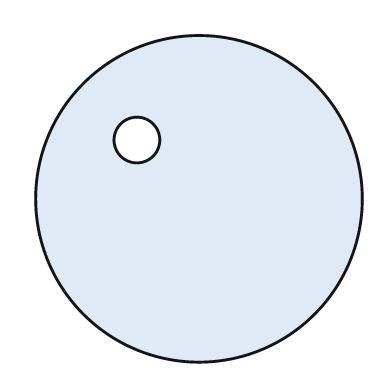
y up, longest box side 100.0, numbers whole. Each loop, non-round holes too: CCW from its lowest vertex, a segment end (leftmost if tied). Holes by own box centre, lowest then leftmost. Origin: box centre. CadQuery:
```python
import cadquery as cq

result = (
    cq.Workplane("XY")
    .moveTo(0.0, 0.0)
    .circle(50.0)
    .moveTo(-19.0, 18.0)
    .circle(7.0)
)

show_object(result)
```